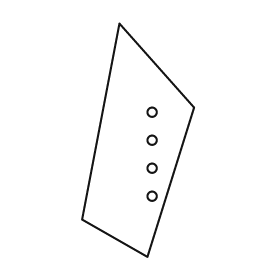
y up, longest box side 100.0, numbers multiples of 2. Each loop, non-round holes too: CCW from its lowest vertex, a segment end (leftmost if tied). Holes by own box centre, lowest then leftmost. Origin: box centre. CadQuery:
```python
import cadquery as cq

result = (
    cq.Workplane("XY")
    .moveTo(4.0, -50.0)
    .lineTo(24.0, 14.0)
    .lineTo(-8.0, 50.0)
    .lineTo(-24.0, -34.0)
    .close()
    .moveTo(6.0, -24.0)
    .circle(2.0)
    .moveTo(6.0, -12.0)
    .circle(2.0)
    .moveTo(6.0, 0.0)
    .circle(2.0)
    .moveTo(6.0, 12.0)
    .circle(2.0)
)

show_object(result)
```